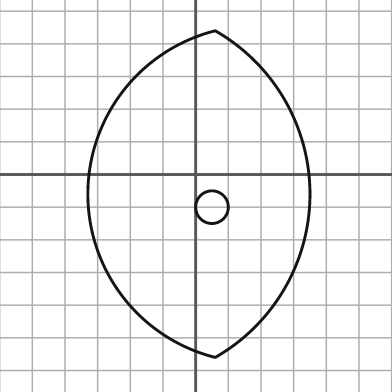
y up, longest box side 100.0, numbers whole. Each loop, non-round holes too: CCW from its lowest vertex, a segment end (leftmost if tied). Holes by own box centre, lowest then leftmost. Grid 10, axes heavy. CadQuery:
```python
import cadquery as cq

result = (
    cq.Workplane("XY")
    .moveTo(6.0, -56.0)
    .threePointArc((35.0, -6.0), (6.0, 44.0))
    .threePointArc((-33.0, -6.0), (6.0, -56.0))
    .close()
    .moveTo(5.0, -10.0)
    .circle(5.0)
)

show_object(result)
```